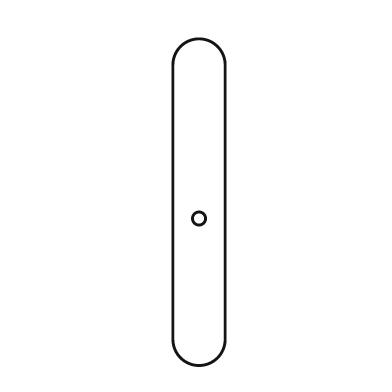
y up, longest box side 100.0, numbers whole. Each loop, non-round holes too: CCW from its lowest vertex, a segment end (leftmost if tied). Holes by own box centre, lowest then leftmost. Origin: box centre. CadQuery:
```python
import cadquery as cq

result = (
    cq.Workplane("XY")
    .moveTo(-8.0, -42.0)
    .threePointArc((0.0, -50.0), (8.0, -42.0))
    .lineTo(8.0, 42.0)
    .threePointArc((0.0, 50.0), (-8.0, 42.0))
    .close()
    .moveTo(0.0, -5.0)
    .circle(2.0)
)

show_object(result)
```